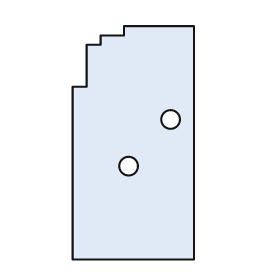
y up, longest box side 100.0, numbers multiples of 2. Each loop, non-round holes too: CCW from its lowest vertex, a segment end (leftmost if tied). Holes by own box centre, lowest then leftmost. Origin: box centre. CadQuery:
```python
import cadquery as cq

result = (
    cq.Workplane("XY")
    .moveTo(-26.0, -50.0)
    .lineTo(26.0, -50.0)
    .lineTo(26.0, 50.0)
    .lineTo(-4.0, 50.0)
    .lineTo(-4.0, 46.0)
    .lineTo(-14.0, 46.0)
    .lineTo(-14.0, 42.0)
    .lineTo(-20.0, 42.0)
    .lineTo(-20.0, 24.0)
    .lineTo(-26.0, 24.0)
    .close()
    .moveTo(-2.0, -10.0)
    .circle(4.0)
    .moveTo(16.0, 10.0)
    .circle(4.0)
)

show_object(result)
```